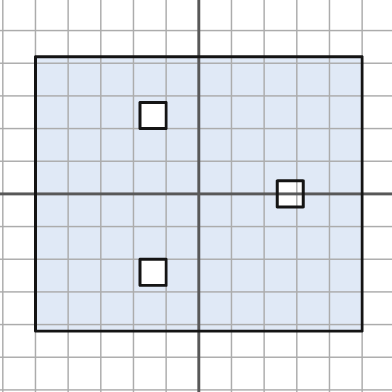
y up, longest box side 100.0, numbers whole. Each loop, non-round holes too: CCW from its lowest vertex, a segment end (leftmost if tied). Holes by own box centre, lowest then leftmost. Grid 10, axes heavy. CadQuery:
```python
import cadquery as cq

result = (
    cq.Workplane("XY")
    .moveTo(-50.0, -42.0)
    .lineTo(50.0, -42.0)
    .lineTo(50.0, 42.0)
    .lineTo(-50.0, 42.0)
    .close()
    .moveTo(-18.0, -28.0)
    .lineTo(-10.0, -28.0)
    .lineTo(-10.0, -20.0)
    .lineTo(-18.0, -20.0)
    .close()
    .moveTo(24.0, -4.0)
    .lineTo(32.0, -4.0)
    .lineTo(32.0, 4.0)
    .lineTo(24.0, 4.0)
    .close()
    .moveTo(-18.0, 20.0)
    .lineTo(-10.0, 20.0)
    .lineTo(-10.0, 28.0)
    .lineTo(-18.0, 28.0)
    .close()
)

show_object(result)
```